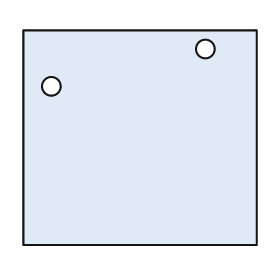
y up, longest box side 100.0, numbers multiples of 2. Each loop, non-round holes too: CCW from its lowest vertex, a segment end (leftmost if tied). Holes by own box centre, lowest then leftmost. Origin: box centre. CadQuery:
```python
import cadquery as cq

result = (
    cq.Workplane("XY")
    .moveTo(-50.0, -46.0)
    .lineTo(50.0, -46.0)
    .lineTo(50.0, 46.0)
    .lineTo(-50.0, 46.0)
    .close()
    .moveTo(-38.0, 22.0)
    .circle(4.0)
    .moveTo(28.0, 38.0)
    .circle(4.0)
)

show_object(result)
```